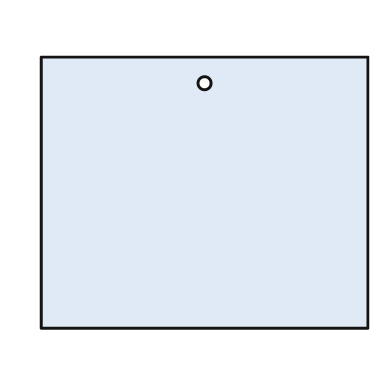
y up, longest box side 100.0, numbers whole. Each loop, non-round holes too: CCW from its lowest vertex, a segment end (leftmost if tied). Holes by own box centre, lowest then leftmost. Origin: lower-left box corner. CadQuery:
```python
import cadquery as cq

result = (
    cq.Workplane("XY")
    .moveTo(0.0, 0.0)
    .lineTo(100.0, 0.0)
    .lineTo(100.0, 83.0)
    .lineTo(0.0, 83.0)
    .close()
    .moveTo(50.0, 75.0)
    .circle(2.0)
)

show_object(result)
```